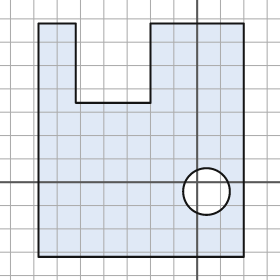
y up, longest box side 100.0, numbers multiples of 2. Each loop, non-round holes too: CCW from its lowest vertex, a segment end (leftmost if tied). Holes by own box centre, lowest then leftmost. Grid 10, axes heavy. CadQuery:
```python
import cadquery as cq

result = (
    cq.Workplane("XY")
    .moveTo(-68.0, -32.0)
    .lineTo(20.0, -32.0)
    .lineTo(20.0, 68.0)
    .lineTo(-20.0, 68.0)
    .lineTo(-20.0, 34.0)
    .lineTo(-52.0, 34.0)
    .lineTo(-52.0, 68.0)
    .lineTo(-68.0, 68.0)
    .close()
    .moveTo(4.0, -4.0)
    .circle(10.0)
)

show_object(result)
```